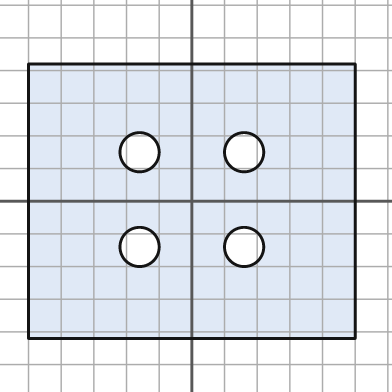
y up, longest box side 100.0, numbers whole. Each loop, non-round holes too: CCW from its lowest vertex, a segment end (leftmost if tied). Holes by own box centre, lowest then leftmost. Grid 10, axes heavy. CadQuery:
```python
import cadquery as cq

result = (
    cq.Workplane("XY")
    .moveTo(-50.0, -42.0)
    .lineTo(50.0, -42.0)
    .lineTo(50.0, 42.0)
    .lineTo(-50.0, 42.0)
    .close()
    .moveTo(-16.0, -14.0)
    .circle(6.0)
    .moveTo(16.0, -14.0)
    .circle(6.0)
    .moveTo(-16.0, 15.0)
    .circle(6.0)
    .moveTo(16.0, 15.0)
    .circle(6.0)
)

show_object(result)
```